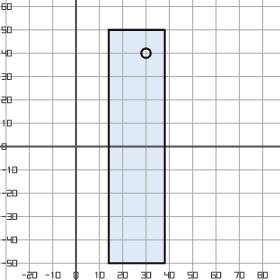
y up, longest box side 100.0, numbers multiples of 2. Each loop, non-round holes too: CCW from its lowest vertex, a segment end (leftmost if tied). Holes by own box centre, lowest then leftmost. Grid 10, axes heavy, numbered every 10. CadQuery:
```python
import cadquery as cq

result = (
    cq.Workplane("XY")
    .moveTo(14.0, -50.0)
    .lineTo(38.0, -50.0)
    .lineTo(38.0, 50.0)
    .lineTo(14.0, 50.0)
    .close()
    .moveTo(30.0, 40.0)
    .circle(2.0)
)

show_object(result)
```